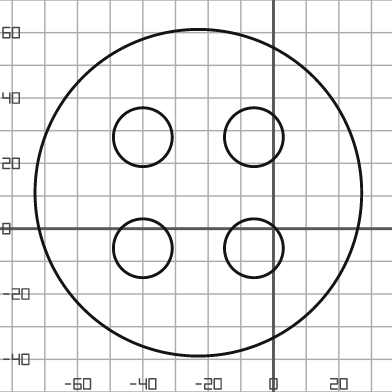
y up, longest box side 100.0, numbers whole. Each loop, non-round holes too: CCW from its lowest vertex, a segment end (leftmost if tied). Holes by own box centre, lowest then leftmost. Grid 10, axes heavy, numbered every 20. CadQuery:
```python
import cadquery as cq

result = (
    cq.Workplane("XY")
    .moveTo(-23.0, 11.0)
    .circle(50.0)
    .moveTo(-40.0, -6.0)
    .circle(9.0)
    .moveTo(-6.0, -6.0)
    .circle(9.0)
    .moveTo(-40.0, 28.0)
    .circle(9.0)
    .moveTo(-6.0, 28.0)
    .circle(9.0)
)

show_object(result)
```